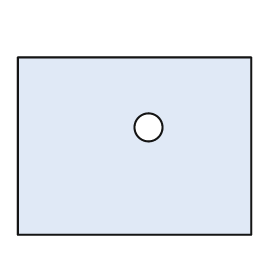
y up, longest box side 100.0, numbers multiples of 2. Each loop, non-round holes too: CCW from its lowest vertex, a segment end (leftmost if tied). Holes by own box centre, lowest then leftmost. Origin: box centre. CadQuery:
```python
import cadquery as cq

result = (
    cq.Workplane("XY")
    .moveTo(-50.0, -38.0)
    .lineTo(50.0, -38.0)
    .lineTo(50.0, 38.0)
    .lineTo(-50.0, 38.0)
    .close()
    .moveTo(6.0, 8.0)
    .circle(6.0)
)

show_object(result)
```